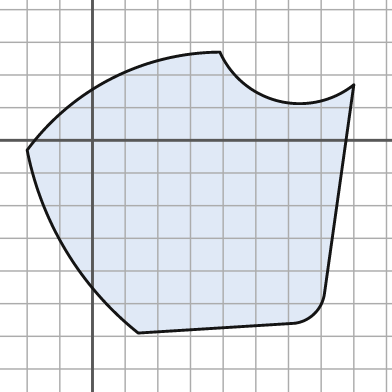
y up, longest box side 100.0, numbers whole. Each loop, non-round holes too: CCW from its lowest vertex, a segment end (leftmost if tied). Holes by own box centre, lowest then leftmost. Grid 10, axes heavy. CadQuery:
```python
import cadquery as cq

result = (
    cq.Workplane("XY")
    .moveTo(14.0, -59.0)
    .lineTo(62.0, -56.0)
    .threePointArc((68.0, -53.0), (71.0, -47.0))
    .lineTo(80.0, 17.0)
    .threePointArc((57.0, 12.0), (39.0, 27.0))
    .threePointArc((6.0, 19.0), (-20.0, -3.0))
    .threePointArc((-8.0, -34.0), (14.0, -59.0))
    .close()
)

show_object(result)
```